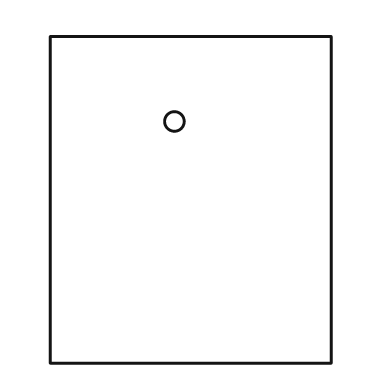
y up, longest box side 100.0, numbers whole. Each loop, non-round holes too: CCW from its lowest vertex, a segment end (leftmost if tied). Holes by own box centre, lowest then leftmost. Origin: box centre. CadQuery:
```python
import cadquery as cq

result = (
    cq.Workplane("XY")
    .moveTo(-43.0, -50.0)
    .lineTo(43.0, -50.0)
    .lineTo(43.0, 50.0)
    .lineTo(-43.0, 50.0)
    .close()
    .moveTo(-5.0, 24.0)
    .circle(3.0)
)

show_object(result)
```